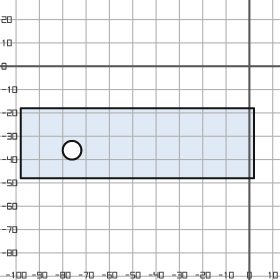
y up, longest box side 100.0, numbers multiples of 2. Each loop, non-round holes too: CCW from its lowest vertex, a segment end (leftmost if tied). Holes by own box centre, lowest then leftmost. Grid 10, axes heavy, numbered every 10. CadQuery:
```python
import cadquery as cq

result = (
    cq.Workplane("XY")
    .moveTo(-98.0, -48.0)
    .lineTo(2.0, -48.0)
    .lineTo(2.0, -18.0)
    .lineTo(-98.0, -18.0)
    .close()
    .moveTo(-76.0, -36.0)
    .circle(4.0)
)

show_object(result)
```